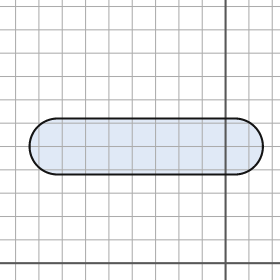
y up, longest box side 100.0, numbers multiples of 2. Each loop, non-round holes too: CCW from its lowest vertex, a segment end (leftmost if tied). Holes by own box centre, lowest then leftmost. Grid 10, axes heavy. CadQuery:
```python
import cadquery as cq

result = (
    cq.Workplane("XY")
    .moveTo(-72.0, 38.0)
    .lineTo(4.0, 38.0)
    .threePointArc((16.0, 50.0), (4.0, 62.0))
    .lineTo(-72.0, 62.0)
    .threePointArc((-84.0, 50.0), (-72.0, 38.0))
    .close()
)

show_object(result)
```